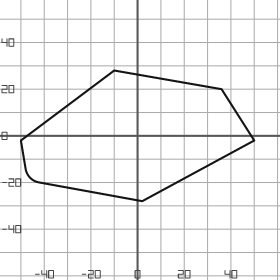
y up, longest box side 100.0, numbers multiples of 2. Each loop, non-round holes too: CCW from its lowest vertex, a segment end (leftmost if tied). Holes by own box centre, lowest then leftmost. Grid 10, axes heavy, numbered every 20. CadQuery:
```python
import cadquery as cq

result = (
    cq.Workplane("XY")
    .moveTo(2.0, -28.0)
    .lineTo(50.0, -2.0)
    .lineTo(36.0, 20.0)
    .lineTo(-10.0, 28.0)
    .lineTo(-50.0, -2.0)
    .lineTo(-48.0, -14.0)
    .threePointArc((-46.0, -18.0), (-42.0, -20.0))
    .close()
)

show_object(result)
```